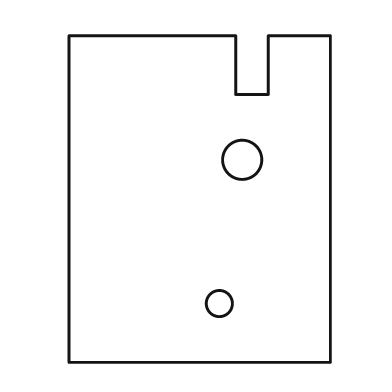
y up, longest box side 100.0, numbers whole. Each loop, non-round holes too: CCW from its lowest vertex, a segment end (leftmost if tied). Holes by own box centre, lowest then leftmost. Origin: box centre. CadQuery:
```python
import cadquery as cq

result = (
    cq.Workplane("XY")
    .moveTo(-40.0, -50.0)
    .lineTo(40.0, -50.0)
    .lineTo(40.0, 50.0)
    .lineTo(21.0, 50.0)
    .lineTo(21.0, 32.0)
    .lineTo(11.0, 32.0)
    .lineTo(11.0, 50.0)
    .lineTo(-40.0, 50.0)
    .close()
    .moveTo(6.0, -32.0)
    .circle(4.0)
    .moveTo(13.0, 12.0)
    .circle(6.0)
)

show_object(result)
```